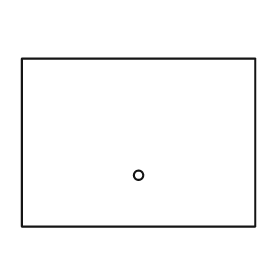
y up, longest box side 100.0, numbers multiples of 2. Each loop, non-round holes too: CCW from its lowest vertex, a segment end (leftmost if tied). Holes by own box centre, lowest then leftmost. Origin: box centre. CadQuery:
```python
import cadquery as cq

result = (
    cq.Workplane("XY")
    .moveTo(-50.0, -36.0)
    .lineTo(50.0, -36.0)
    .lineTo(50.0, 36.0)
    .lineTo(-50.0, 36.0)
    .close()
    .moveTo(0.0, -14.0)
    .circle(2.0)
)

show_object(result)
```